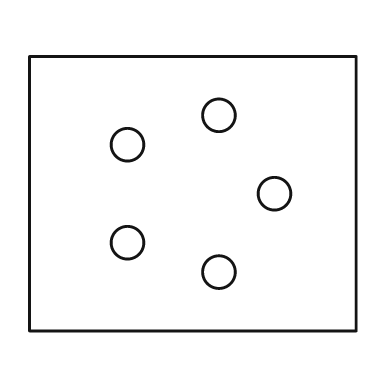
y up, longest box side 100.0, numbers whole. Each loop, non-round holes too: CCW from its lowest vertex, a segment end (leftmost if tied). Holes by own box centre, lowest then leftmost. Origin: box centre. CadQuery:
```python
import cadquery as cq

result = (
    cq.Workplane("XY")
    .moveTo(-50.0, -42.0)
    .lineTo(50.0, -42.0)
    .lineTo(50.0, 42.0)
    .lineTo(-50.0, 42.0)
    .close()
    .moveTo(8.0, -24.0)
    .circle(5.0)
    .moveTo(-20.0, -15.0)
    .circle(5.0)
    .moveTo(25.0, 0.0)
    .circle(5.0)
    .moveTo(-20.0, 15.0)
    .circle(5.0)
    .moveTo(8.0, 24.0)
    .circle(5.0)
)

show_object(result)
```